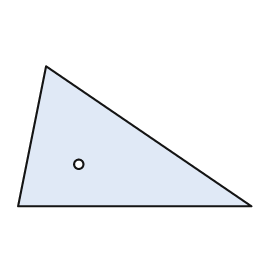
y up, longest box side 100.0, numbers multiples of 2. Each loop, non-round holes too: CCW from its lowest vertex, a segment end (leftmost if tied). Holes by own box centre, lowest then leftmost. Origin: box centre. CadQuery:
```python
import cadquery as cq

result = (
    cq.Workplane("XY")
    .moveTo(-50.0, -30.0)
    .lineTo(50.0, -30.0)
    .lineTo(-38.0, 30.0)
    .close()
    .moveTo(-24.0, -12.0)
    .circle(2.0)
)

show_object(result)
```